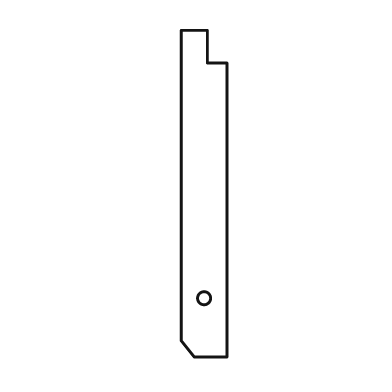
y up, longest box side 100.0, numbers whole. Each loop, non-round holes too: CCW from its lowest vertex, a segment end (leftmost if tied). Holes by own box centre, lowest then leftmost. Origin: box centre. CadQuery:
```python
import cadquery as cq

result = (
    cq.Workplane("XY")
    .moveTo(-3.0, -50.0)
    .lineTo(7.0, -50.0)
    .lineTo(7.0, 40.0)
    .lineTo(1.0, 40.0)
    .lineTo(1.0, 50.0)
    .lineTo(-7.0, 50.0)
    .lineTo(-7.0, -45.0)
    .close()
    .moveTo(0.0, -32.0)
    .circle(2.0)
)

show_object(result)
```